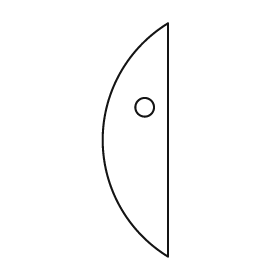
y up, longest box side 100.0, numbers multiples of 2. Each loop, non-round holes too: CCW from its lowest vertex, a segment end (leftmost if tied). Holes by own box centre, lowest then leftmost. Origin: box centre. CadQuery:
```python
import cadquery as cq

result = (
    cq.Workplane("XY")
    .moveTo(14.0, -50.0)
    .lineTo(14.0, 50.0)
    .threePointArc((-14.0, 0.0), (14.0, -50.0))
    .close()
    .moveTo(4.0, 14.0)
    .circle(4.0)
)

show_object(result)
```